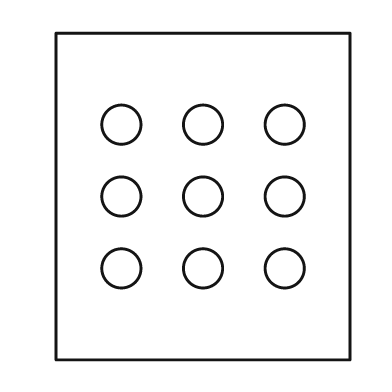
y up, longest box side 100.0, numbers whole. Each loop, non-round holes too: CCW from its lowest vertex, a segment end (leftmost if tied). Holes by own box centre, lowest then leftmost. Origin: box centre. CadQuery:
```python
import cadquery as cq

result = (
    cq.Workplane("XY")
    .moveTo(-45.0, -50.0)
    .lineTo(45.0, -50.0)
    .lineTo(45.0, 50.0)
    .lineTo(-45.0, 50.0)
    .close()
    .moveTo(-25.0, -22.0)
    .circle(6.0)
    .moveTo(0.0, -22.0)
    .circle(6.0)
    .moveTo(25.0, -22.0)
    .circle(6.0)
    .moveTo(-25.0, 0.0)
    .circle(6.0)
    .moveTo(0.0, 0.0)
    .circle(6.0)
    .moveTo(25.0, 0.0)
    .circle(6.0)
    .moveTo(-25.0, 22.0)
    .circle(6.0)
    .moveTo(0.0, 22.0)
    .circle(6.0)
    .moveTo(25.0, 22.0)
    .circle(6.0)
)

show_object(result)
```